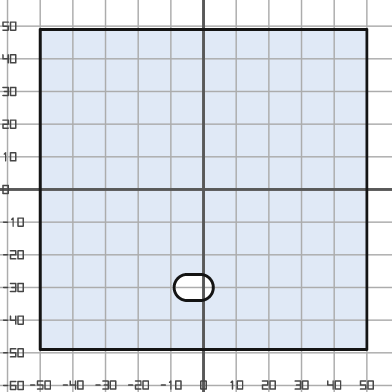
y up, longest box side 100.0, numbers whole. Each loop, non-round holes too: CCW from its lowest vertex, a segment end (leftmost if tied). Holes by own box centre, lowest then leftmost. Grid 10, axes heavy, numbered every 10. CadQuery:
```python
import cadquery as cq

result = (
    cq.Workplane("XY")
    .moveTo(-50.0, -49.0)
    .lineTo(50.0, -49.0)
    .lineTo(50.0, 49.0)
    .lineTo(-50.0, 49.0)
    .close()
    .moveTo(-5.0, -34.0)
    .lineTo(-1.0, -34.0)
    .threePointArc((3.0, -30.0), (-1.0, -26.0))
    .lineTo(-5.0, -26.0)
    .threePointArc((-9.0, -30.0), (-5.0, -34.0))
    .close()
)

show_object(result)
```